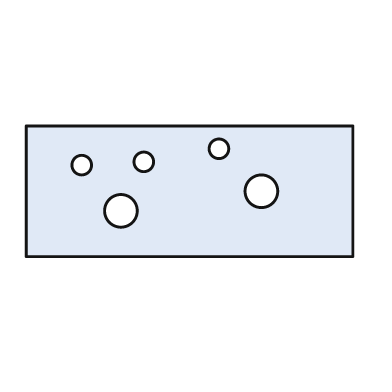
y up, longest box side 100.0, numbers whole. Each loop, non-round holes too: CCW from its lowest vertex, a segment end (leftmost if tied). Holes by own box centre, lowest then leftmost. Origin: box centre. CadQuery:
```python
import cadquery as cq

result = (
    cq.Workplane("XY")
    .moveTo(-50.0, -20.0)
    .lineTo(50.0, -20.0)
    .lineTo(50.0, 20.0)
    .lineTo(-50.0, 20.0)
    .close()
    .moveTo(-21.0, -6.0)
    .circle(5.0)
    .moveTo(22.0, 0.0)
    .circle(5.0)
    .moveTo(-33.0, 8.0)
    .circle(3.0)
    .moveTo(-14.0, 9.0)
    .circle(3.0)
    .moveTo(9.0, 13.0)
    .circle(3.0)
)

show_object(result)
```